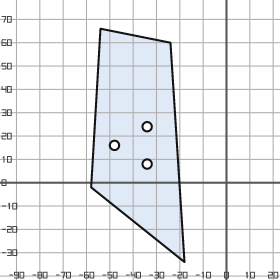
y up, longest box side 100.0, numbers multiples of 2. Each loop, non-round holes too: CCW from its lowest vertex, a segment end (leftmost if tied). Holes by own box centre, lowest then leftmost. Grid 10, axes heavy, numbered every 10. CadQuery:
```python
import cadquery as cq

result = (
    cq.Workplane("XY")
    .moveTo(-18.0, -34.0)
    .lineTo(-24.0, 60.0)
    .lineTo(-54.0, 66.0)
    .lineTo(-58.0, -2.0)
    .close()
    .moveTo(-34.0, 8.0)
    .circle(2.0)
    .moveTo(-48.0, 16.0)
    .circle(2.0)
    .moveTo(-34.0, 24.0)
    .circle(2.0)
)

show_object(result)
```